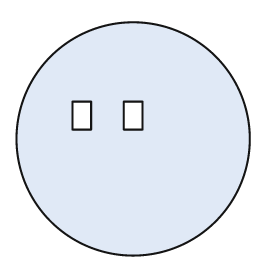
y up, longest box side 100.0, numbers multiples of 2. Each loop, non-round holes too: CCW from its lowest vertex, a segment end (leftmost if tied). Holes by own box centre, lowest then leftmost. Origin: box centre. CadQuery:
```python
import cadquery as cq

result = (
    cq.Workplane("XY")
    .moveTo(0.0, 0.0)
    .circle(50.0)
    .moveTo(-26.0, 4.0)
    .lineTo(-18.0, 4.0)
    .lineTo(-18.0, 16.0)
    .lineTo(-26.0, 16.0)
    .close()
    .moveTo(-4.0, 4.0)
    .lineTo(4.0, 4.0)
    .lineTo(4.0, 16.0)
    .lineTo(-4.0, 16.0)
    .close()
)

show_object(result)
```